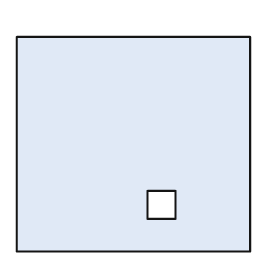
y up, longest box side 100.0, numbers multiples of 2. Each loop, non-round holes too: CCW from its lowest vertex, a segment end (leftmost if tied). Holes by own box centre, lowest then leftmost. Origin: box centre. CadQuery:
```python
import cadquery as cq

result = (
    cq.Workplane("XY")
    .moveTo(-50.0, -46.0)
    .lineTo(50.0, -46.0)
    .lineTo(50.0, 46.0)
    .lineTo(-50.0, 46.0)
    .close()
    .moveTo(6.0, -32.0)
    .lineTo(18.0, -32.0)
    .lineTo(18.0, -20.0)
    .lineTo(6.0, -20.0)
    .close()
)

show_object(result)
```